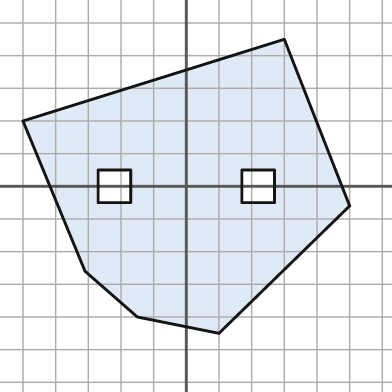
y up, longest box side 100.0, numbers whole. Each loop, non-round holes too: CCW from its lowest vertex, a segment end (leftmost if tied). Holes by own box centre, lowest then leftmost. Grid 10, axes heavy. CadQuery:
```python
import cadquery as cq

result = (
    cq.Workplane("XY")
    .moveTo(10.0, -45.0)
    .lineTo(50.0, -6.0)
    .lineTo(30.0, 45.0)
    .lineTo(-50.0, 20.0)
    .lineTo(-31.0, -26.0)
    .lineTo(-15.0, -40.0)
    .close()
    .moveTo(-27.0, -5.0)
    .lineTo(-17.0, -5.0)
    .lineTo(-17.0, 5.0)
    .lineTo(-27.0, 5.0)
    .close()
    .moveTo(17.0, -5.0)
    .lineTo(27.0, -5.0)
    .lineTo(27.0, 5.0)
    .lineTo(17.0, 5.0)
    .close()
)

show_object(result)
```